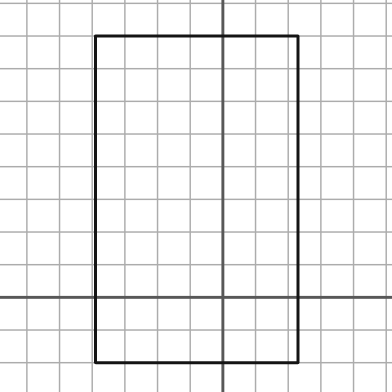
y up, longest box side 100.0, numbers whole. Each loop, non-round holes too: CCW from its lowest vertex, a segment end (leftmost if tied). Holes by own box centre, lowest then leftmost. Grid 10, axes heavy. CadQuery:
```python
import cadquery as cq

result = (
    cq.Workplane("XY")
    .moveTo(-39.0, -20.0)
    .lineTo(23.0, -20.0)
    .lineTo(23.0, 80.0)
    .lineTo(-39.0, 80.0)
    .close()
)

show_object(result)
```